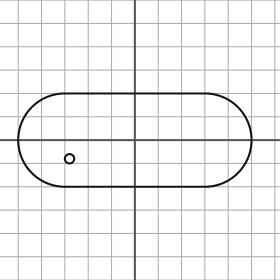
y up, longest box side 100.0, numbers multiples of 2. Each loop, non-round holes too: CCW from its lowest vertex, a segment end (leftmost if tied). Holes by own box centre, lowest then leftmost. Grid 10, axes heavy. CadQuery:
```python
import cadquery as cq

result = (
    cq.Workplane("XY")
    .moveTo(-30.0, -20.0)
    .lineTo(30.0, -20.0)
    .threePointArc((50.0, 0.0), (30.0, 20.0))
    .lineTo(-30.0, 20.0)
    .threePointArc((-50.0, 0.0), (-30.0, -20.0))
    .close()
    .moveTo(-28.0, -8.0)
    .circle(2.0)
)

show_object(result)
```